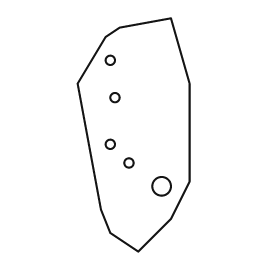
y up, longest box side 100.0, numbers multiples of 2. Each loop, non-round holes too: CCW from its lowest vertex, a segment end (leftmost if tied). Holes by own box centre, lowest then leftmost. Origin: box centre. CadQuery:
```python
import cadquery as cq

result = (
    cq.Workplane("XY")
    .moveTo(2.0, -50.0)
    .lineTo(16.0, -36.0)
    .lineTo(24.0, -20.0)
    .lineTo(24.0, 22.0)
    .lineTo(16.0, 50.0)
    .lineTo(-6.0, 46.0)
    .lineTo(-12.0, 42.0)
    .lineTo(-24.0, 22.0)
    .lineTo(-14.0, -32.0)
    .lineTo(-10.0, -42.0)
    .close()
    .moveTo(12.0, -22.0)
    .circle(4.0)
    .moveTo(-2.0, -12.0)
    .circle(2.0)
    .moveTo(-10.0, -4.0)
    .circle(2.0)
    .moveTo(-8.0, 16.0)
    .circle(2.0)
    .moveTo(-10.0, 32.0)
    .circle(2.0)
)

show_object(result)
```